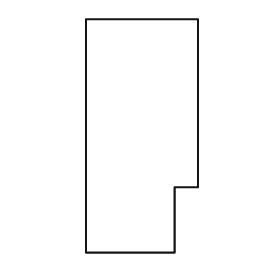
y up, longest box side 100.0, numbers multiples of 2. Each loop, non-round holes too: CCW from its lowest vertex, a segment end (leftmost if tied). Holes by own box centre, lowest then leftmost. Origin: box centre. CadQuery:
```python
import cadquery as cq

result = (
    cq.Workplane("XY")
    .moveTo(-24.0, -50.0)
    .lineTo(14.0, -50.0)
    .lineTo(14.0, -22.0)
    .lineTo(24.0, -22.0)
    .lineTo(24.0, 50.0)
    .lineTo(-24.0, 50.0)
    .close()
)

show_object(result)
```